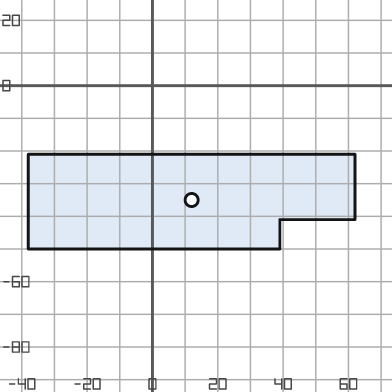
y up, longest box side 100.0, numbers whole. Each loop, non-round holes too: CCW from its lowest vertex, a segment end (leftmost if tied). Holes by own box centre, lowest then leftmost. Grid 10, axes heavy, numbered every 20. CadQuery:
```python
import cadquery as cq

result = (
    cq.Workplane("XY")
    .moveTo(-38.0, -50.0)
    .lineTo(39.0, -50.0)
    .lineTo(39.0, -41.0)
    .lineTo(62.0, -41.0)
    .lineTo(62.0, -21.0)
    .lineTo(-38.0, -21.0)
    .close()
    .moveTo(12.0, -35.0)
    .circle(2.0)
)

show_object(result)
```